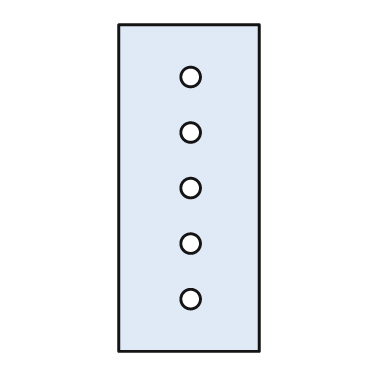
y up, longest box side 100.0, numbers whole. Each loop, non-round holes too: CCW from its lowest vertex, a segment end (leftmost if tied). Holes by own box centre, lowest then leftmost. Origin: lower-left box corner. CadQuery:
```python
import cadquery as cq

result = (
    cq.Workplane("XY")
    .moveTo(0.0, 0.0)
    .lineTo(43.0, 0.0)
    .lineTo(43.0, 100.0)
    .lineTo(0.0, 100.0)
    .close()
    .moveTo(22.0, 16.0)
    .circle(3.0)
    .moveTo(22.0, 33.0)
    .circle(3.0)
    .moveTo(22.0, 50.0)
    .circle(3.0)
    .moveTo(22.0, 67.0)
    .circle(3.0)
    .moveTo(22.0, 84.0)
    .circle(3.0)
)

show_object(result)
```